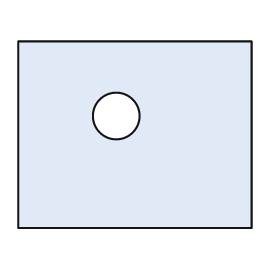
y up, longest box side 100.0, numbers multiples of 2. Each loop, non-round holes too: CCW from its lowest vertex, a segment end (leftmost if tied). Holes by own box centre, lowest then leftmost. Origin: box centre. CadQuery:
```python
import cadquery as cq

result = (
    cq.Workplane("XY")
    .moveTo(-50.0, -40.0)
    .lineTo(50.0, -40.0)
    .lineTo(50.0, 40.0)
    .lineTo(-50.0, 40.0)
    .close()
    .moveTo(-8.0, 8.0)
    .circle(10.0)
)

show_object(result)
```